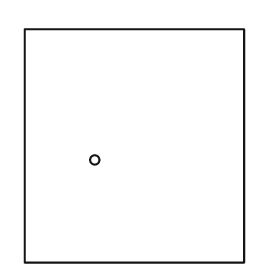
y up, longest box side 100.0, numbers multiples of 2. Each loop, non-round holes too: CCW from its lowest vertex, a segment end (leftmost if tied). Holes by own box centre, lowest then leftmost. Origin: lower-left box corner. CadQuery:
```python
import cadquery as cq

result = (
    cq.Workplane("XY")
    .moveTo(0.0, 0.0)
    .lineTo(94.0, 0.0)
    .lineTo(94.0, 100.0)
    .lineTo(0.0, 100.0)
    .close()
    .moveTo(30.0, 44.0)
    .circle(2.0)
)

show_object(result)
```